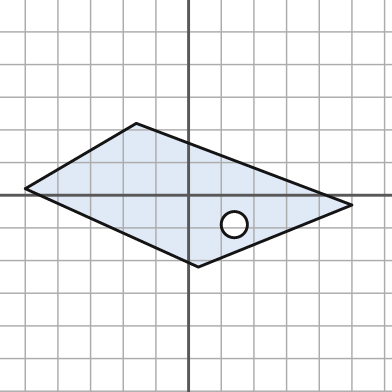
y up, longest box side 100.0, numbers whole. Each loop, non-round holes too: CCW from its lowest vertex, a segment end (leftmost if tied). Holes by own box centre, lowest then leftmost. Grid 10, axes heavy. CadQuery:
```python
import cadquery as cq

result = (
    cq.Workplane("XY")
    .moveTo(3.0, -22.0)
    .lineTo(50.0, -3.0)
    .lineTo(-16.0, 22.0)
    .lineTo(-50.0, 2.0)
    .close()
    .moveTo(14.0, -9.0)
    .circle(4.0)
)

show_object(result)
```